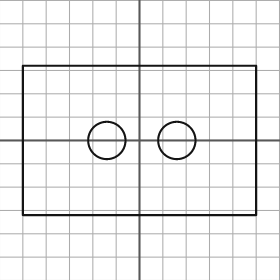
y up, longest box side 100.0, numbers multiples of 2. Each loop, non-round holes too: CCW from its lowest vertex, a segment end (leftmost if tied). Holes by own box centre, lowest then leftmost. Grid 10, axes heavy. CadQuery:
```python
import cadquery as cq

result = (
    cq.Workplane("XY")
    .moveTo(-50.0, -32.0)
    .lineTo(50.0, -32.0)
    .lineTo(50.0, 32.0)
    .lineTo(-50.0, 32.0)
    .close()
    .moveTo(-14.0, 0.0)
    .circle(8.0)
    .moveTo(16.0, 0.0)
    .circle(8.0)
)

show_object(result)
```